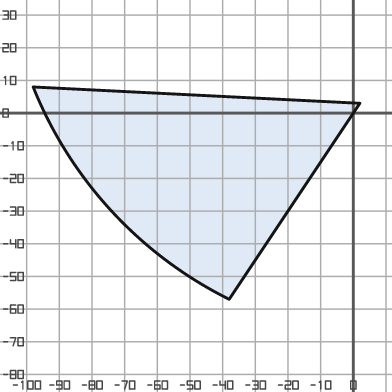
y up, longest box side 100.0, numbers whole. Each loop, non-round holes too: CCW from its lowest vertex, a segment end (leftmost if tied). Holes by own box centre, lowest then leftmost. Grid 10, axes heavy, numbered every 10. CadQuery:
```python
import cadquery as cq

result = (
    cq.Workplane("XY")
    .moveTo(-38.0, -57.0)
    .lineTo(2.0, 3.0)
    .lineTo(-98.0, 8.0)
    .threePointArc((-74.0, -30.0), (-38.0, -57.0))
    .close()
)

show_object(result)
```